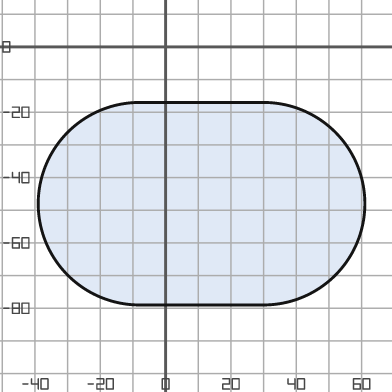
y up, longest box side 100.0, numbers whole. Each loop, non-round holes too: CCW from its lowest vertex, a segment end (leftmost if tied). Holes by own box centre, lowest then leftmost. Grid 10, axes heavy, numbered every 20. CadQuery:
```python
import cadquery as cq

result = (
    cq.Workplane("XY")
    .moveTo(-8.0, -79.0)
    .lineTo(30.0, -79.0)
    .threePointArc((61.0, -48.0), (30.0, -17.0))
    .lineTo(-8.0, -17.0)
    .threePointArc((-39.0, -48.0), (-8.0, -79.0))
    .close()
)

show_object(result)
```